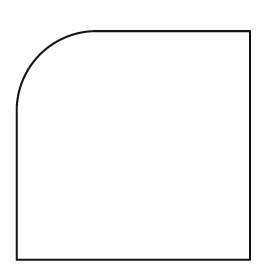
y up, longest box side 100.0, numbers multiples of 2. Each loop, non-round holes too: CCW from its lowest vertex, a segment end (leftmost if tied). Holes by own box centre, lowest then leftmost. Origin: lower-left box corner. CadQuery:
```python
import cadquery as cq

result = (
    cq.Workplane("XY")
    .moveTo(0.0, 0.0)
    .lineTo(100.0, 0.0)
    .lineTo(100.0, 98.0)
    .lineTo(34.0, 98.0)
    .threePointArc((10.0, 88.0), (0.0, 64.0))
    .close()
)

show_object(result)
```